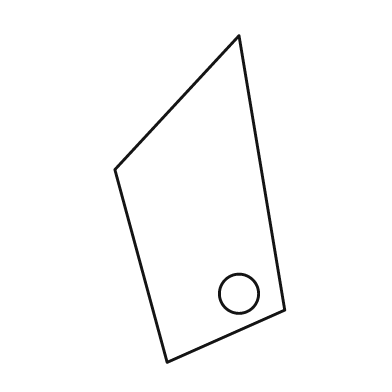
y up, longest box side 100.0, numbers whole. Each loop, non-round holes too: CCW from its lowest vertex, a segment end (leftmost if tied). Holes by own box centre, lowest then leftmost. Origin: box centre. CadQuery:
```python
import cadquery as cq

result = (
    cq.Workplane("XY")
    .moveTo(-10.0, -50.0)
    .lineTo(26.0, -34.0)
    .lineTo(12.0, 50.0)
    .lineTo(-26.0, 9.0)
    .close()
    .moveTo(12.0, -29.0)
    .circle(6.0)
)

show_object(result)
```